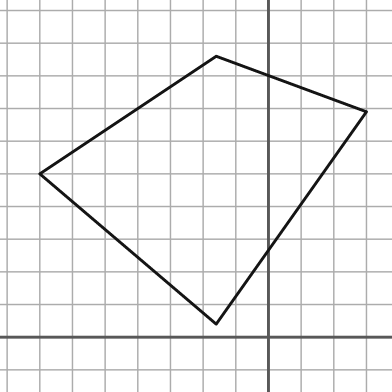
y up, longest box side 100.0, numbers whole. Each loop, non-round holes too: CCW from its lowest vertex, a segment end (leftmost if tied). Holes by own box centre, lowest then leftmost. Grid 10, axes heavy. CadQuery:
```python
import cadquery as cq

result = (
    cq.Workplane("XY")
    .moveTo(-16.0, 4.0)
    .lineTo(30.0, 69.0)
    .lineTo(-16.0, 86.0)
    .lineTo(-70.0, 50.0)
    .close()
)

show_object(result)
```